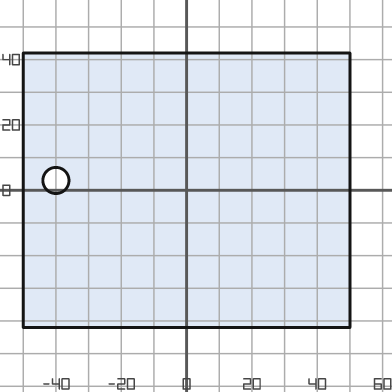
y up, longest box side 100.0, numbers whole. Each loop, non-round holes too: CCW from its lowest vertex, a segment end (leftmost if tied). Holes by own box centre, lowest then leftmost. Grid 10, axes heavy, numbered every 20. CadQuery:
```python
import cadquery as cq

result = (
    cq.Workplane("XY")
    .moveTo(-50.0, -42.0)
    .lineTo(50.0, -42.0)
    .lineTo(50.0, 42.0)
    .lineTo(-50.0, 42.0)
    .close()
    .moveTo(-40.0, 3.0)
    .circle(4.0)
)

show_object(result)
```